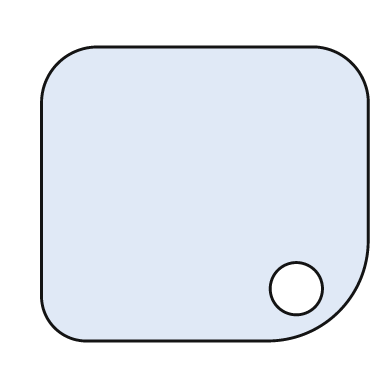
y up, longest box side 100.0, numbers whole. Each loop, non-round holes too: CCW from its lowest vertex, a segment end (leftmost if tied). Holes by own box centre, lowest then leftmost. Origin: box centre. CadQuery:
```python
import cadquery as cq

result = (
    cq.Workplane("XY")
    .moveTo(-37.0, -45.0)
    .lineTo(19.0, -45.0)
    .threePointArc((41.0, -36.0), (50.0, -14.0))
    .lineTo(50.0, 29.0)
    .threePointArc((45.0, 40.0), (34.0, 45.0))
    .lineTo(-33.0, 45.0)
    .threePointArc((-45.0, 40.0), (-50.0, 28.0))
    .lineTo(-50.0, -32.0)
    .threePointArc((-46.0, -41.0), (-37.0, -45.0))
    .close()
    .moveTo(28.0, -29.0)
    .circle(8.0)
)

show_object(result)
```